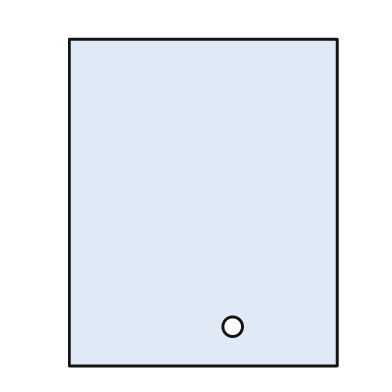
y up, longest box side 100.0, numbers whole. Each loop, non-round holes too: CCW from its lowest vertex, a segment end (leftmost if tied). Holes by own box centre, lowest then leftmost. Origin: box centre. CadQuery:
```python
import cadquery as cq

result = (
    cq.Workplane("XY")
    .moveTo(-41.0, -50.0)
    .lineTo(41.0, -50.0)
    .lineTo(41.0, 50.0)
    .lineTo(-41.0, 50.0)
    .close()
    .moveTo(9.0, -38.0)
    .circle(3.0)
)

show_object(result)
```